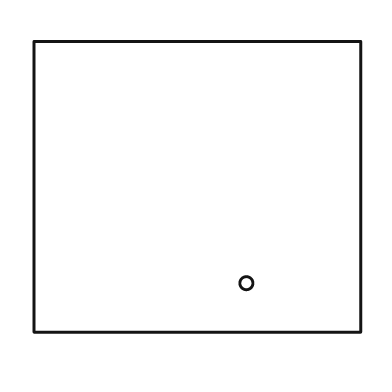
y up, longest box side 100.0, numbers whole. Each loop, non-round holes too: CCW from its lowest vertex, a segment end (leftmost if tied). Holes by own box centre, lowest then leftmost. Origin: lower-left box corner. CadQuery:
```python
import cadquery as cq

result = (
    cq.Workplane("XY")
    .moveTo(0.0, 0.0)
    .lineTo(100.0, 0.0)
    .lineTo(100.0, 89.0)
    .lineTo(0.0, 89.0)
    .close()
    .moveTo(65.0, 15.0)
    .circle(2.0)
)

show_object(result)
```